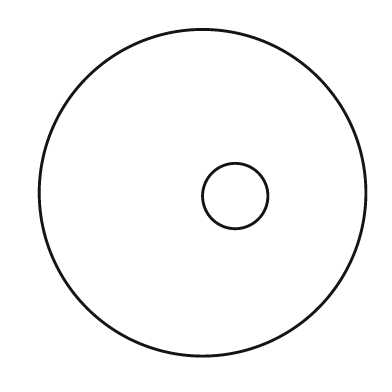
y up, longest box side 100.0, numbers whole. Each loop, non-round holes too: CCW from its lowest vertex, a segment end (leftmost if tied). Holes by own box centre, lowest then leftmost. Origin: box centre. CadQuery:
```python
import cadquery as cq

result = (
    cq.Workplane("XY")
    .moveTo(0.0, 0.0)
    .circle(50.0)
    .moveTo(10.0, -1.0)
    .circle(10.0)
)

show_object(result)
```